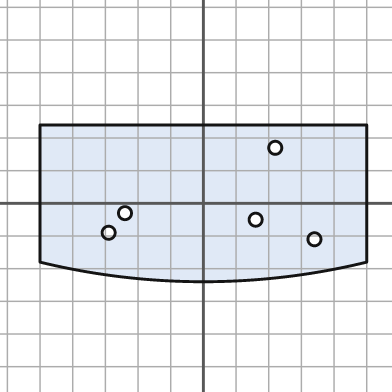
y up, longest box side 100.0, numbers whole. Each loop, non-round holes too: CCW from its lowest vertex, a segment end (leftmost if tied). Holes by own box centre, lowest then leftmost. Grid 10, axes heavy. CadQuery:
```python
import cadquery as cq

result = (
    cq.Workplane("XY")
    .moveTo(-50.0, -18.0)
    .threePointArc((0.0, -24.0), (50.0, -18.0))
    .lineTo(50.0, 24.0)
    .lineTo(-50.0, 24.0)
    .close()
    .moveTo(34.0, -11.0)
    .circle(2.0)
    .moveTo(-29.0, -9.0)
    .circle(2.0)
    .moveTo(16.0, -5.0)
    .circle(2.0)
    .moveTo(-24.0, -3.0)
    .circle(2.0)
    .moveTo(22.0, 17.0)
    .circle(2.0)
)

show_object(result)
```